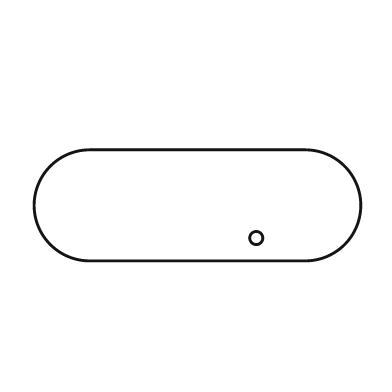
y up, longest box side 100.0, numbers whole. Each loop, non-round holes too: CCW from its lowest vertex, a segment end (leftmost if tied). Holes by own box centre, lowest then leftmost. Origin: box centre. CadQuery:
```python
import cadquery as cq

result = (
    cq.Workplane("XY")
    .moveTo(-33.0, -17.0)
    .lineTo(33.0, -17.0)
    .threePointArc((50.0, 0.0), (33.0, 17.0))
    .lineTo(-33.0, 17.0)
    .threePointArc((-50.0, 0.0), (-33.0, -17.0))
    .close()
    .moveTo(18.0, -10.0)
    .circle(2.0)
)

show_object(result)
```